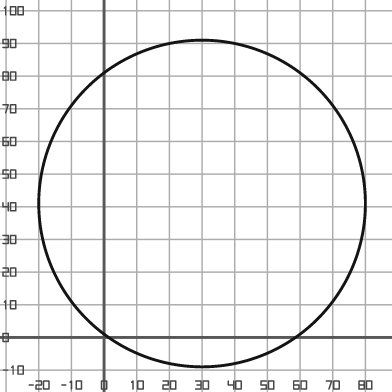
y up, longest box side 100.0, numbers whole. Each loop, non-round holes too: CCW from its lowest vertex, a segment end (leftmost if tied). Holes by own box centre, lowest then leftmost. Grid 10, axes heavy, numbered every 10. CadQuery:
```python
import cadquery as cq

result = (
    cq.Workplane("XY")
    .moveTo(30.0, 41.0)
    .circle(50.0)
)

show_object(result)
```